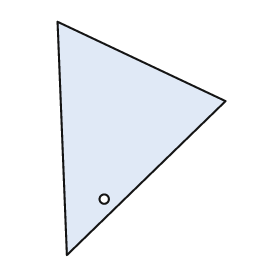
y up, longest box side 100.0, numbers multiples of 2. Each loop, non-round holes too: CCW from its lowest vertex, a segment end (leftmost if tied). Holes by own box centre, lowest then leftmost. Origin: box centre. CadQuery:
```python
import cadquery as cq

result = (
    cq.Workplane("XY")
    .moveTo(-32.0, -50.0)
    .lineTo(36.0, 16.0)
    .lineTo(-36.0, 50.0)
    .close()
    .moveTo(-16.0, -26.0)
    .circle(2.0)
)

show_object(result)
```